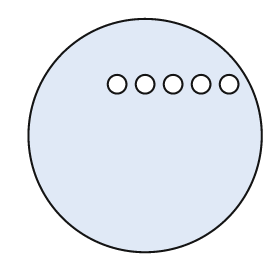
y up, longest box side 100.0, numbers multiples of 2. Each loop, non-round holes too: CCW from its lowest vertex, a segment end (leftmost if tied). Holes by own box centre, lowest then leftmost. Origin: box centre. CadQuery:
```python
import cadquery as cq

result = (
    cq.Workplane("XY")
    .moveTo(0.0, 0.0)
    .circle(50.0)
    .moveTo(-12.0, 22.0)
    .circle(4.0)
    .moveTo(0.0, 22.0)
    .circle(4.0)
    .moveTo(12.0, 22.0)
    .circle(4.0)
    .moveTo(24.0, 22.0)
    .circle(4.0)
    .moveTo(36.0, 22.0)
    .circle(4.0)
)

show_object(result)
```